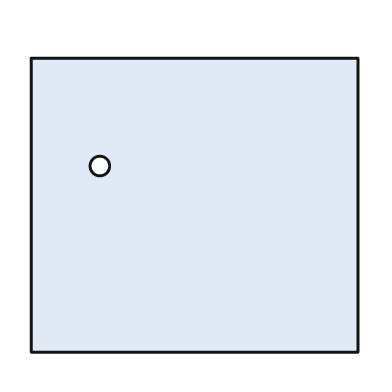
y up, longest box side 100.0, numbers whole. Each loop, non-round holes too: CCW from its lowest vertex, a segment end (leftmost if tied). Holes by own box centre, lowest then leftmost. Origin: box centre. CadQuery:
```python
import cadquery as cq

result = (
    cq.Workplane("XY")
    .moveTo(-50.0, -45.0)
    .lineTo(50.0, -45.0)
    .lineTo(50.0, 45.0)
    .lineTo(-50.0, 45.0)
    .close()
    .moveTo(-29.0, 12.0)
    .circle(3.0)
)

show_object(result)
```